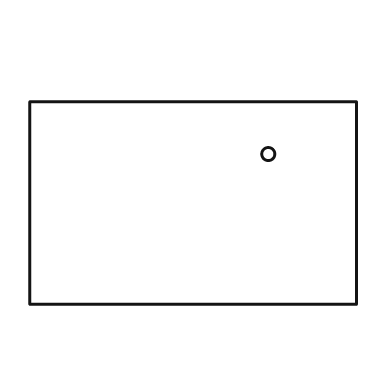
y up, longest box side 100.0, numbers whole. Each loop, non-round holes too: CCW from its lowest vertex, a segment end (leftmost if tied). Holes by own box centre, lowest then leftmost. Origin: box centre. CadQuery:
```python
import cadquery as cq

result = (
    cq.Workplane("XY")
    .moveTo(-50.0, -31.0)
    .lineTo(50.0, -31.0)
    .lineTo(50.0, 31.0)
    .lineTo(-50.0, 31.0)
    .close()
    .moveTo(23.0, 15.0)
    .circle(2.0)
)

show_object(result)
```